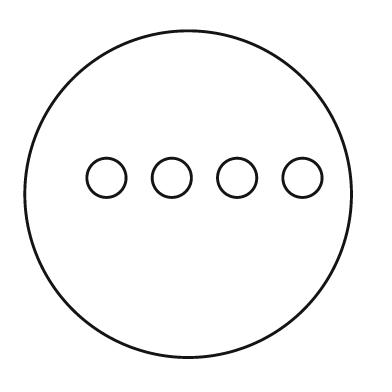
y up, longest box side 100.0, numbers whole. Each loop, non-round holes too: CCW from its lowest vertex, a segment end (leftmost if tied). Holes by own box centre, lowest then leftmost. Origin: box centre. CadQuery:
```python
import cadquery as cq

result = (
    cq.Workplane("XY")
    .moveTo(0.0, 0.0)
    .circle(50.0)
    .moveTo(-25.0, 5.0)
    .circle(6.0)
    .moveTo(-5.0, 5.0)
    .circle(6.0)
    .moveTo(15.0, 5.0)
    .circle(6.0)
    .moveTo(35.0, 5.0)
    .circle(6.0)
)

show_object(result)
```